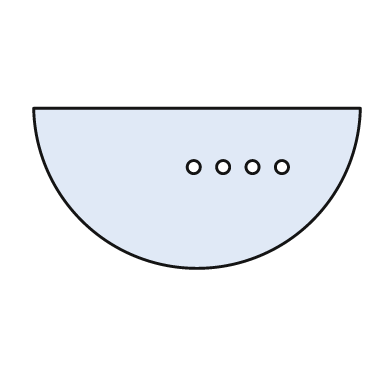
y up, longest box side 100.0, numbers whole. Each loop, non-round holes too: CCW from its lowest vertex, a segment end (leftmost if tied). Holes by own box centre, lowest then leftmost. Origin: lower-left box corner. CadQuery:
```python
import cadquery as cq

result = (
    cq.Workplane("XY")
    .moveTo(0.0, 49.0)
    .threePointArc((50.0, 0.0), (100.0, 49.0))
    .close()
    .moveTo(49.0, 31.0)
    .circle(2.0)
    .moveTo(58.0, 31.0)
    .circle(2.0)
    .moveTo(67.0, 31.0)
    .circle(2.0)
    .moveTo(76.0, 31.0)
    .circle(2.0)
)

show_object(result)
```